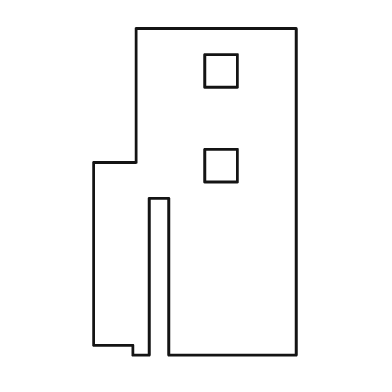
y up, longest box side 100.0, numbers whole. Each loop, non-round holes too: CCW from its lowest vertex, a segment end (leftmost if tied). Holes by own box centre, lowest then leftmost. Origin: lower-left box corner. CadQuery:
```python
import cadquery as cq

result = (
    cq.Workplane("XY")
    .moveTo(12.0, 0.0)
    .lineTo(17.0, 0.0)
    .lineTo(17.0, 48.0)
    .lineTo(23.0, 48.0)
    .lineTo(23.0, 0.0)
    .lineTo(62.0, 0.0)
    .lineTo(62.0, 100.0)
    .lineTo(13.0, 100.0)
    .lineTo(13.0, 59.0)
    .lineTo(0.0, 59.0)
    .lineTo(0.0, 3.0)
    .lineTo(12.0, 3.0)
    .close()
    .moveTo(34.0, 53.0)
    .lineTo(44.0, 53.0)
    .lineTo(44.0, 63.0)
    .lineTo(34.0, 63.0)
    .close()
    .moveTo(34.0, 82.0)
    .lineTo(44.0, 82.0)
    .lineTo(44.0, 92.0)
    .lineTo(34.0, 92.0)
    .close()
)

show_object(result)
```